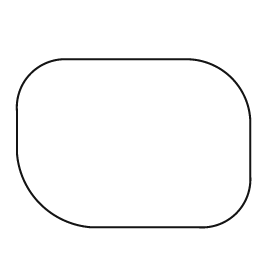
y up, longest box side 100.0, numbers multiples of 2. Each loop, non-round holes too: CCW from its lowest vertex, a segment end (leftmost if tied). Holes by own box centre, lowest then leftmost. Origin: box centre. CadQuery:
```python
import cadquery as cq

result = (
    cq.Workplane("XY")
    .moveTo(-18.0, -36.0)
    .lineTo(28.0, -36.0)
    .threePointArc((44.0, -30.0), (50.0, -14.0))
    .lineTo(50.0, 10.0)
    .threePointArc((42.0, 28.0), (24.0, 36.0))
    .lineTo(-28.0, 36.0)
    .threePointArc((-44.0, 30.0), (-50.0, 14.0))
    .lineTo(-50.0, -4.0)
    .threePointArc((-40.0, -26.0), (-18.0, -36.0))
    .close()
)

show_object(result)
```